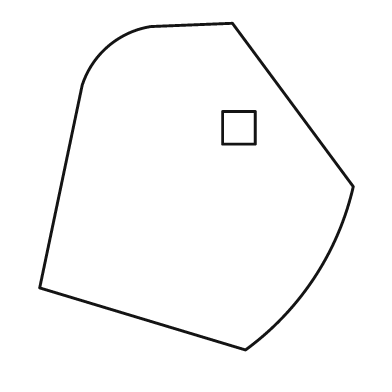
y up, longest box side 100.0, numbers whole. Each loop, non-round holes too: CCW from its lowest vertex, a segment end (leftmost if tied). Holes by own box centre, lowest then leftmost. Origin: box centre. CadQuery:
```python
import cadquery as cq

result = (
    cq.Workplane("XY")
    .moveTo(15.0, -50.0)
    .threePointArc((36.0, -28.0), (48.0, 0.0))
    .lineTo(11.0, 50.0)
    .lineTo(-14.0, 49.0)
    .threePointArc((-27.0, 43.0), (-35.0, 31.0))
    .lineTo(-48.0, -31.0)
    .close()
    .moveTo(8.0, 13.0)
    .lineTo(18.0, 13.0)
    .lineTo(18.0, 23.0)
    .lineTo(8.0, 23.0)
    .close()
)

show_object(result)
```